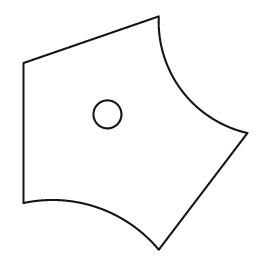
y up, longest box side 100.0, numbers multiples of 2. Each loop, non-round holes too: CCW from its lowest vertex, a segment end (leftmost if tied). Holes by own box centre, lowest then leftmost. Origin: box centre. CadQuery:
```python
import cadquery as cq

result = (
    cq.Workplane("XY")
    .moveTo(10.0, -50.0)
    .lineTo(48.0, 0.0)
    .threePointArc((20.0, 18.0), (10.0, 50.0))
    .lineTo(-48.0, 30.0)
    .lineTo(-48.0, -30.0)
    .threePointArc((-16.0, -32.0), (10.0, -50.0))
    .close()
    .moveTo(-12.0, 8.0)
    .circle(6.0)
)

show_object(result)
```